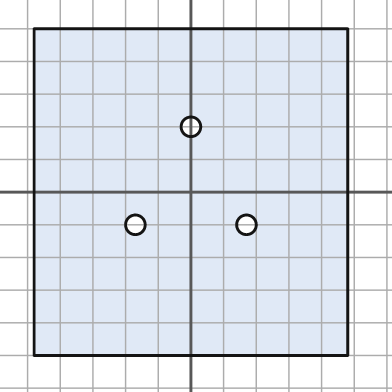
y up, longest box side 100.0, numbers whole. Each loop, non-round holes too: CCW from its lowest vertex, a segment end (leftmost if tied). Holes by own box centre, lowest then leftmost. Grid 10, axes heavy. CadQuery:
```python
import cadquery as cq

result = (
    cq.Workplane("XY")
    .moveTo(-48.0, -50.0)
    .lineTo(48.0, -50.0)
    .lineTo(48.0, 50.0)
    .lineTo(-48.0, 50.0)
    .close()
    .moveTo(-17.0, -10.0)
    .circle(3.0)
    .moveTo(17.0, -10.0)
    .circle(3.0)
    .moveTo(0.0, 20.0)
    .circle(3.0)
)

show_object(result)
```